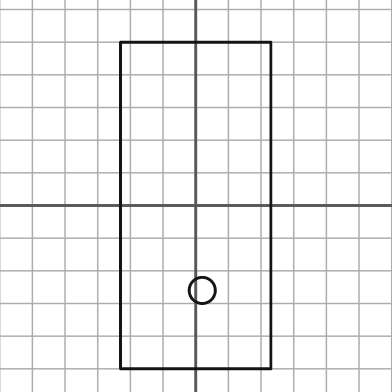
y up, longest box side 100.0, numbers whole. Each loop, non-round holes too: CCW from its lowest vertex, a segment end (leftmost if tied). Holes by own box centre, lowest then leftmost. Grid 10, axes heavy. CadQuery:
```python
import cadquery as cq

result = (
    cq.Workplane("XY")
    .moveTo(-23.0, -50.0)
    .lineTo(23.0, -50.0)
    .lineTo(23.0, 50.0)
    .lineTo(-23.0, 50.0)
    .close()
    .moveTo(2.0, -26.0)
    .circle(4.0)
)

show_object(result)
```